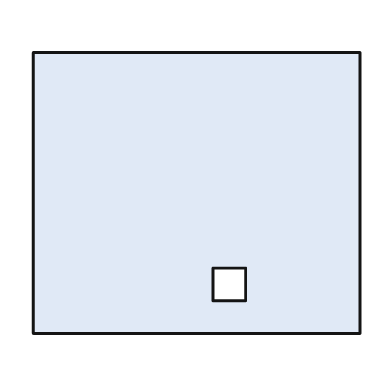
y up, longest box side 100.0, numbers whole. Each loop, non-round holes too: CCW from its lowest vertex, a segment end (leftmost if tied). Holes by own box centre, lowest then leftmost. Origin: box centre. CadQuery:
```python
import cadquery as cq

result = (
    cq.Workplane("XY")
    .moveTo(-50.0, -43.0)
    .lineTo(50.0, -43.0)
    .lineTo(50.0, 43.0)
    .lineTo(-50.0, 43.0)
    .close()
    .moveTo(5.0, -33.0)
    .lineTo(15.0, -33.0)
    .lineTo(15.0, -23.0)
    .lineTo(5.0, -23.0)
    .close()
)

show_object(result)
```